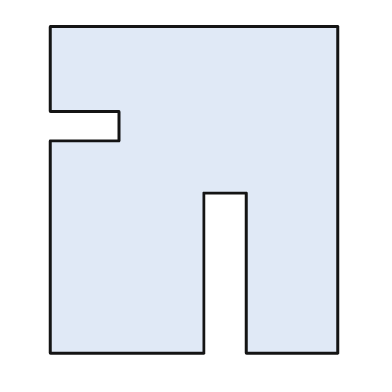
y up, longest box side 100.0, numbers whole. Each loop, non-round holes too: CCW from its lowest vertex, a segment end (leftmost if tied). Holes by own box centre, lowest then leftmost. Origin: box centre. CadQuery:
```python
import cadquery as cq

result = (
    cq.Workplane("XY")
    .moveTo(-44.0, -50.0)
    .lineTo(3.0, -50.0)
    .lineTo(3.0, -1.0)
    .lineTo(16.0, -1.0)
    .lineTo(16.0, -50.0)
    .lineTo(44.0, -50.0)
    .lineTo(44.0, 50.0)
    .lineTo(-44.0, 50.0)
    .lineTo(-44.0, 24.0)
    .lineTo(-23.0, 24.0)
    .lineTo(-23.0, 15.0)
    .lineTo(-44.0, 15.0)
    .close()
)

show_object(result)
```